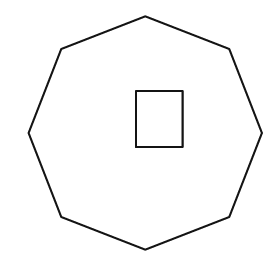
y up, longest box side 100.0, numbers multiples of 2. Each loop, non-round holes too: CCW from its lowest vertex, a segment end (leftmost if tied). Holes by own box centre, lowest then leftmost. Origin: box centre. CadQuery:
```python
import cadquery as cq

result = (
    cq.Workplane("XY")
    .moveTo(0.0, -50.0)
    .lineTo(36.0, -36.0)
    .lineTo(50.0, 0.0)
    .lineTo(36.0, 36.0)
    .lineTo(0.0, 50.0)
    .lineTo(-36.0, 36.0)
    .lineTo(-50.0, 0.0)
    .lineTo(-36.0, -36.0)
    .close()
    .moveTo(-4.0, -6.0)
    .lineTo(16.0, -6.0)
    .lineTo(16.0, 18.0)
    .lineTo(-4.0, 18.0)
    .close()
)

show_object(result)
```